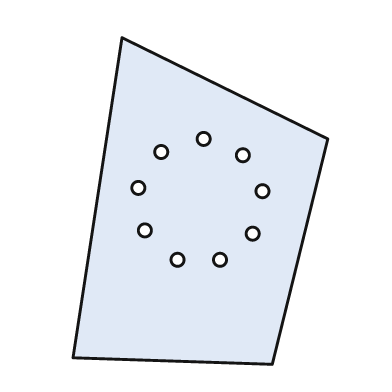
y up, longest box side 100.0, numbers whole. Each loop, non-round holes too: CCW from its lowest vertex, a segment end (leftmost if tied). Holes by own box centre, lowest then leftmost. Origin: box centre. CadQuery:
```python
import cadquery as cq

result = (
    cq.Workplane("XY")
    .moveTo(22.0, -50.0)
    .lineTo(39.0, 19.0)
    .lineTo(-24.0, 50.0)
    .lineTo(-39.0, -48.0)
    .close()
    .moveTo(-7.0, -18.0)
    .circle(2.0)
    .moveTo(6.0, -18.0)
    .circle(2.0)
    .moveTo(16.0, -10.0)
    .circle(2.0)
    .moveTo(-17.0, -9.0)
    .circle(2.0)
    .moveTo(19.0, 3.0)
    .circle(2.0)
    .moveTo(-19.0, 4.0)
    .circle(2.0)
    .moveTo(13.0, 14.0)
    .circle(2.0)
    .moveTo(-12.0, 15.0)
    .circle(2.0)
    .moveTo(1.0, 19.0)
    .circle(2.0)
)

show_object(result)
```